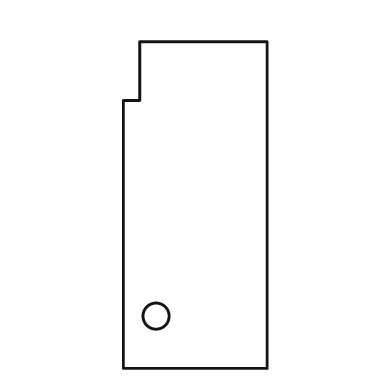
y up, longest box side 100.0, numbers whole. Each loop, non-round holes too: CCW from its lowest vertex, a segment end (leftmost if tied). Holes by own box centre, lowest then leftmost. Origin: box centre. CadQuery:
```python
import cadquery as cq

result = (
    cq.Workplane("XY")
    .moveTo(-22.0, -50.0)
    .lineTo(22.0, -50.0)
    .lineTo(22.0, 50.0)
    .lineTo(-17.0, 50.0)
    .lineTo(-17.0, 32.0)
    .lineTo(-22.0, 32.0)
    .close()
    .moveTo(-12.0, -34.0)
    .circle(4.0)
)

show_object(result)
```